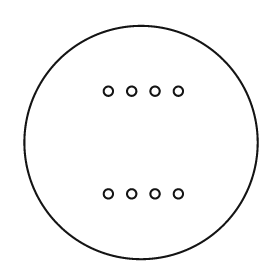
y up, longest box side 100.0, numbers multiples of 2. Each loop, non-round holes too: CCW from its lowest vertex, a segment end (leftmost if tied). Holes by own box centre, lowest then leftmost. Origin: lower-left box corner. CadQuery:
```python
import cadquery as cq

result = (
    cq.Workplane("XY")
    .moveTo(50.0, 50.0)
    .circle(50.0)
    .moveTo(36.0, 28.0)
    .circle(2.0)
    .moveTo(46.0, 28.0)
    .circle(2.0)
    .moveTo(56.0, 28.0)
    .circle(2.0)
    .moveTo(66.0, 28.0)
    .circle(2.0)
    .moveTo(36.0, 72.0)
    .circle(2.0)
    .moveTo(46.0, 72.0)
    .circle(2.0)
    .moveTo(56.0, 72.0)
    .circle(2.0)
    .moveTo(66.0, 72.0)
    .circle(2.0)
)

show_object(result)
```